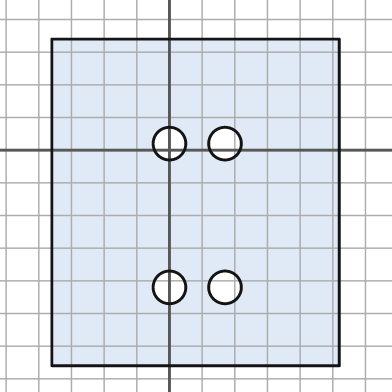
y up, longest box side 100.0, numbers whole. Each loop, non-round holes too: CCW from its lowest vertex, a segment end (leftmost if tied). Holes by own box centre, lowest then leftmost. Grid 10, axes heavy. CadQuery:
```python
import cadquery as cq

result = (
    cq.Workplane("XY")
    .moveTo(-36.0, -66.0)
    .lineTo(52.0, -66.0)
    .lineTo(52.0, 34.0)
    .lineTo(-36.0, 34.0)
    .close()
    .moveTo(0.0, -42.0)
    .circle(5.0)
    .moveTo(17.0, -42.0)
    .circle(5.0)
    .moveTo(0.0, 2.0)
    .circle(5.0)
    .moveTo(17.0, 2.0)
    .circle(5.0)
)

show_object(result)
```